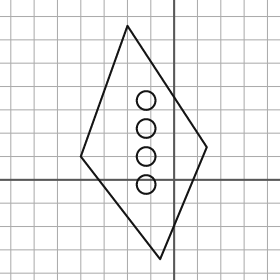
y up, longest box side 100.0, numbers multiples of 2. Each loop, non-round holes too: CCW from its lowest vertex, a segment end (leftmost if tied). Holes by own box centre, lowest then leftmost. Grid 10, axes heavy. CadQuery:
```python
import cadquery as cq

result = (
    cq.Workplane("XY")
    .moveTo(-6.0, -34.0)
    .lineTo(14.0, 14.0)
    .lineTo(-20.0, 66.0)
    .lineTo(-40.0, 10.0)
    .close()
    .moveTo(-12.0, -2.0)
    .circle(4.0)
    .moveTo(-12.0, 10.0)
    .circle(4.0)
    .moveTo(-12.0, 22.0)
    .circle(4.0)
    .moveTo(-12.0, 34.0)
    .circle(4.0)
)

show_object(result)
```